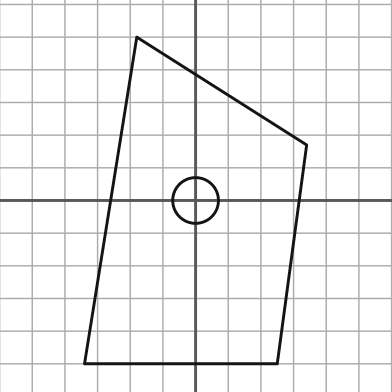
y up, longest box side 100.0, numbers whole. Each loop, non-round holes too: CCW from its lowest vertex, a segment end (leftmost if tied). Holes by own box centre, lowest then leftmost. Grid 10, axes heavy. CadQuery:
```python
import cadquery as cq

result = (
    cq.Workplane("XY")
    .moveTo(-34.0, -50.0)
    .lineTo(25.0, -50.0)
    .lineTo(34.0, 17.0)
    .lineTo(-18.0, 50.0)
    .close()
    .moveTo(0.0, 0.0)
    .circle(7.0)
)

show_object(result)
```